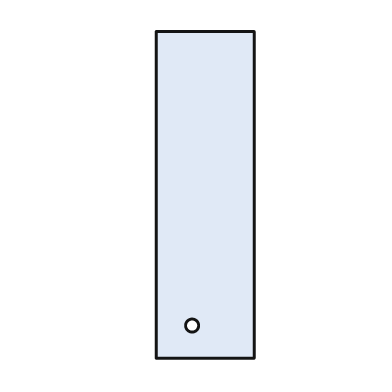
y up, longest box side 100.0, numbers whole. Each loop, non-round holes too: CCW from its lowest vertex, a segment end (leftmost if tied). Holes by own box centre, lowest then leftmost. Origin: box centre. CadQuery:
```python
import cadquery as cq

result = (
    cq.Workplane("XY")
    .moveTo(-15.0, -50.0)
    .lineTo(15.0, -50.0)
    .lineTo(15.0, 50.0)
    .lineTo(-15.0, 50.0)
    .close()
    .moveTo(-4.0, -40.0)
    .circle(2.0)
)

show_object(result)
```